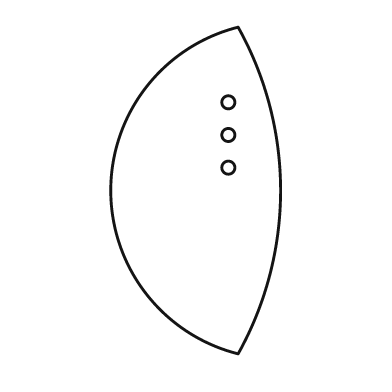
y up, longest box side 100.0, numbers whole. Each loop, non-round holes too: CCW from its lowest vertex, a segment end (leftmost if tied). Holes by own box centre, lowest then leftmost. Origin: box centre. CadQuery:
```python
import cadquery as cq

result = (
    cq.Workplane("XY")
    .moveTo(13.0, -50.0)
    .threePointArc((26.0, 0.0), (13.0, 50.0))
    .threePointArc((-26.0, 0.0), (13.0, -50.0))
    .close()
    .moveTo(10.0, 7.0)
    .circle(2.0)
    .moveTo(10.0, 17.0)
    .circle(2.0)
    .moveTo(10.0, 27.0)
    .circle(2.0)
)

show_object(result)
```